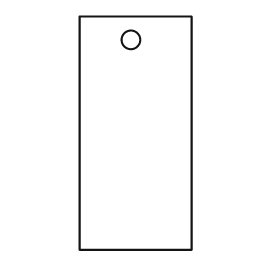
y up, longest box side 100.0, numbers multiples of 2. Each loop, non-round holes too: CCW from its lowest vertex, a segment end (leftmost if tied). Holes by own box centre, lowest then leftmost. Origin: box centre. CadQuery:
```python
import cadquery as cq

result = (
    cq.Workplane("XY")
    .moveTo(-24.0, -50.0)
    .lineTo(24.0, -50.0)
    .lineTo(24.0, 50.0)
    .lineTo(-24.0, 50.0)
    .close()
    .moveTo(-2.0, 40.0)
    .circle(4.0)
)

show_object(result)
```